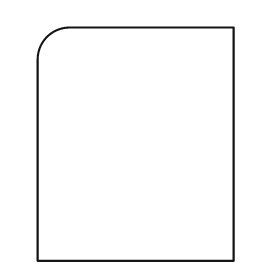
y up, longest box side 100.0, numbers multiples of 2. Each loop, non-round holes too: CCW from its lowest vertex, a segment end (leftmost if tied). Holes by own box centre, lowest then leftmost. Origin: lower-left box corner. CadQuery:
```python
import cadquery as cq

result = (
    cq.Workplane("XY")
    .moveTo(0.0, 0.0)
    .lineTo(84.0, 0.0)
    .lineTo(84.0, 100.0)
    .lineTo(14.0, 100.0)
    .threePointArc((4.0, 96.0), (0.0, 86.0))
    .close()
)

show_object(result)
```